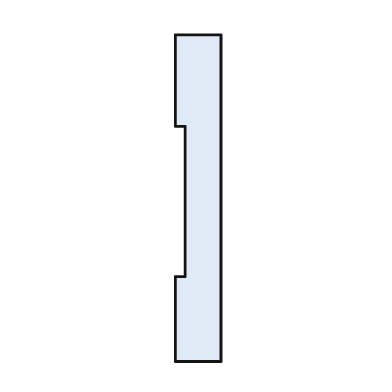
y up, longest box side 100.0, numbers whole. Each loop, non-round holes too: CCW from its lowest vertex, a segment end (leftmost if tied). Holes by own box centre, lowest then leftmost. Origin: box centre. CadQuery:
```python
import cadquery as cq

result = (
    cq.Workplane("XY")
    .moveTo(-7.0, -50.0)
    .lineTo(7.0, -50.0)
    .lineTo(7.0, 50.0)
    .lineTo(-7.0, 50.0)
    .lineTo(-7.0, 22.0)
    .lineTo(-4.0, 22.0)
    .lineTo(-4.0, -24.0)
    .lineTo(-7.0, -24.0)
    .close()
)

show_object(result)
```